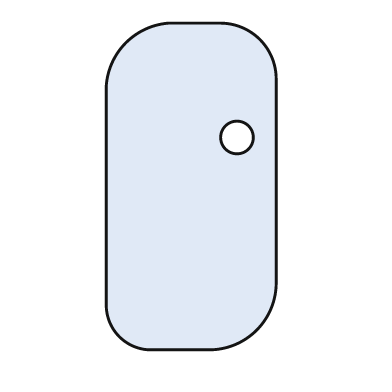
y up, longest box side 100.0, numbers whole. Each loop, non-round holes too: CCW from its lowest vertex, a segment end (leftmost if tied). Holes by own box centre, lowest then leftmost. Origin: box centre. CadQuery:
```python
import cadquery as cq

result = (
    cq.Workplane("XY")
    .moveTo(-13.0, -50.0)
    .lineTo(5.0, -50.0)
    .threePointArc((20.0, -44.0), (26.0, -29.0))
    .lineTo(26.0, 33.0)
    .threePointArc((21.0, 45.0), (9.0, 50.0))
    .lineTo(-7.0, 50.0)
    .threePointArc((-20.0, 44.0), (-26.0, 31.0))
    .lineTo(-26.0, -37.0)
    .threePointArc((-22.0, -46.0), (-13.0, -50.0))
    .close()
    .moveTo(14.0, 15.0)
    .circle(5.0)
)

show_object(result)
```